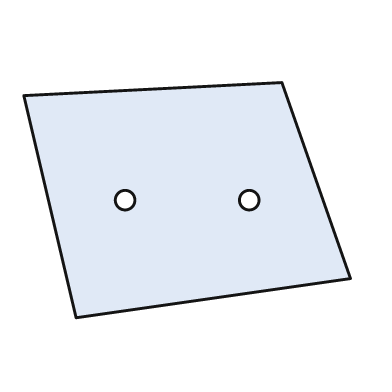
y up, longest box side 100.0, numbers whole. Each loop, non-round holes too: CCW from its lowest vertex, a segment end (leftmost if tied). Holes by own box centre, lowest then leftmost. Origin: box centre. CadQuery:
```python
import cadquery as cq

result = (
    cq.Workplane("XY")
    .moveTo(-34.0, -36.0)
    .lineTo(50.0, -24.0)
    .lineTo(29.0, 36.0)
    .lineTo(-50.0, 32.0)
    .close()
    .moveTo(-19.0, 0.0)
    .circle(3.0)
    .moveTo(19.0, 0.0)
    .circle(3.0)
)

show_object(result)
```